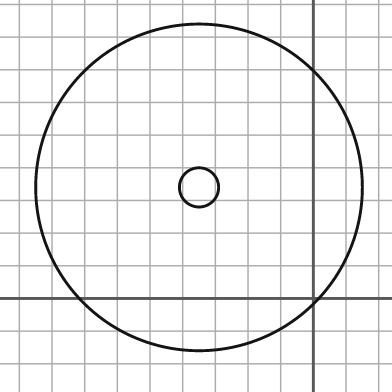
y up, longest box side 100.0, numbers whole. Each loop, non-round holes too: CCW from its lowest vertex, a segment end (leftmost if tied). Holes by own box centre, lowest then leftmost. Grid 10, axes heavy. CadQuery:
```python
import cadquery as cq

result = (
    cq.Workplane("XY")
    .moveTo(-35.0, 34.0)
    .circle(50.0)
    .moveTo(-35.0, 34.0)
    .circle(6.0)
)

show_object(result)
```